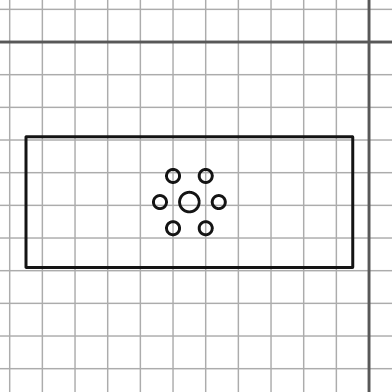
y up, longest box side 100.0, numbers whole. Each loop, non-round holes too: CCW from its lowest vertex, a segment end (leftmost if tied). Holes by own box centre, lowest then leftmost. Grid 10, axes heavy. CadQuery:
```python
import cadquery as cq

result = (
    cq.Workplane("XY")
    .moveTo(-105.0, -69.0)
    .lineTo(-5.0, -69.0)
    .lineTo(-5.0, -29.0)
    .lineTo(-105.0, -29.0)
    .close()
    .moveTo(-60.0, -57.0)
    .circle(2.0)
    .moveTo(-50.0, -57.0)
    .circle(2.0)
    .moveTo(-64.0, -49.0)
    .circle(2.0)
    .moveTo(-55.0, -49.0)
    .circle(3.0)
    .moveTo(-46.0, -49.0)
    .circle(2.0)
    .moveTo(-60.0, -41.0)
    .circle(2.0)
    .moveTo(-50.0, -41.0)
    .circle(2.0)
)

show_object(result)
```